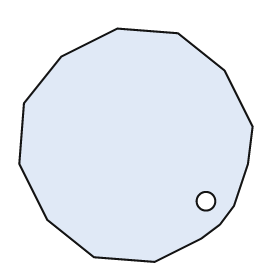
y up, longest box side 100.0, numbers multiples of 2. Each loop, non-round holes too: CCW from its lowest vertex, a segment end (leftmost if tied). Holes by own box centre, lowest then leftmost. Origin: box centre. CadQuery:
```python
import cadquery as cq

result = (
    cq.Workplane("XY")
    .moveTo(8.0, -50.0)
    .lineTo(28.0, -40.0)
    .lineTo(36.0, -34.0)
    .lineTo(42.0, -26.0)
    .lineTo(48.0, -8.0)
    .lineTo(50.0, 8.0)
    .lineTo(38.0, 32.0)
    .lineTo(18.0, 48.0)
    .lineTo(-8.0, 50.0)
    .lineTo(-32.0, 38.0)
    .lineTo(-48.0, 18.0)
    .lineTo(-50.0, -8.0)
    .lineTo(-38.0, -32.0)
    .lineTo(-18.0, -48.0)
    .close()
    .moveTo(30.0, -24.0)
    .circle(4.0)
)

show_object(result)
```